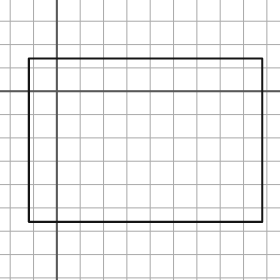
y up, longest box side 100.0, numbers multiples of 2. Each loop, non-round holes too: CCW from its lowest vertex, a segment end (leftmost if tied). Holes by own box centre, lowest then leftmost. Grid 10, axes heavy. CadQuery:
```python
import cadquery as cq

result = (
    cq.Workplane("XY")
    .moveTo(-12.0, -56.0)
    .lineTo(88.0, -56.0)
    .lineTo(88.0, 14.0)
    .lineTo(-12.0, 14.0)
    .close()
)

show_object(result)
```